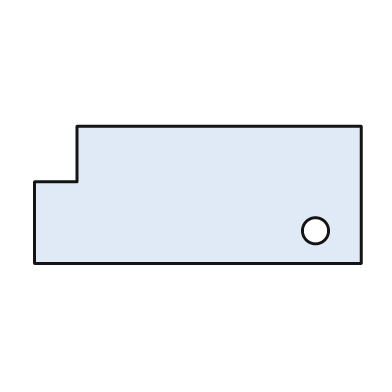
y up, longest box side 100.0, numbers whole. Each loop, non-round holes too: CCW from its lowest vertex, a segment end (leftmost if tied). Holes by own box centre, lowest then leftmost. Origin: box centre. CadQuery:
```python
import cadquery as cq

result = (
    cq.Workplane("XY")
    .moveTo(-50.0, -21.0)
    .lineTo(50.0, -21.0)
    .lineTo(50.0, 21.0)
    .lineTo(-37.0, 21.0)
    .lineTo(-37.0, 4.0)
    .lineTo(-50.0, 4.0)
    .close()
    .moveTo(36.0, -11.0)
    .circle(4.0)
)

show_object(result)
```